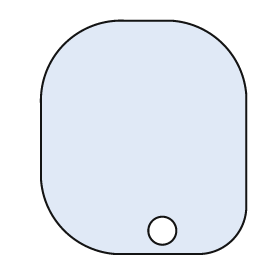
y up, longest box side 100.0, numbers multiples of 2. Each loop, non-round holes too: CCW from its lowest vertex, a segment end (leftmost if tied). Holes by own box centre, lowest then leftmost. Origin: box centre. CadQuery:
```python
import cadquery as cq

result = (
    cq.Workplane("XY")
    .moveTo(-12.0, -50.0)
    .lineTo(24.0, -50.0)
    .threePointArc((38.0, -44.0), (44.0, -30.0))
    .lineTo(44.0, 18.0)
    .threePointArc((34.0, 40.0), (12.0, 50.0))
    .lineTo(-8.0, 50.0)
    .threePointArc((-34.0, 40.0), (-44.0, 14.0))
    .lineTo(-44.0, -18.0)
    .threePointArc((-34.0, -40.0), (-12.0, -50.0))
    .close()
    .moveTo(8.0, -40.0)
    .circle(6.0)
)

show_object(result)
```